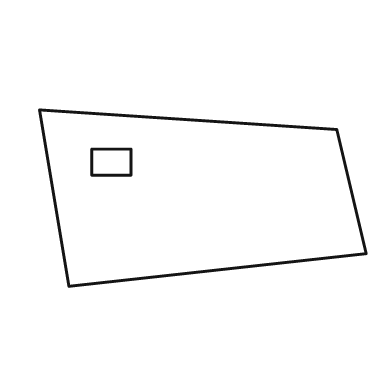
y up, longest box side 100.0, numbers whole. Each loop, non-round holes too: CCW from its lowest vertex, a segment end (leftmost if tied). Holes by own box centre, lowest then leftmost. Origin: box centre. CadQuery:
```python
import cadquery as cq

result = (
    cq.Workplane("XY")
    .moveTo(-41.0, -27.0)
    .lineTo(50.0, -17.0)
    .lineTo(41.0, 21.0)
    .lineTo(-50.0, 27.0)
    .close()
    .moveTo(-34.0, 7.0)
    .lineTo(-22.0, 7.0)
    .lineTo(-22.0, 15.0)
    .lineTo(-34.0, 15.0)
    .close()
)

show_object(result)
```